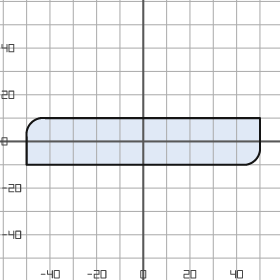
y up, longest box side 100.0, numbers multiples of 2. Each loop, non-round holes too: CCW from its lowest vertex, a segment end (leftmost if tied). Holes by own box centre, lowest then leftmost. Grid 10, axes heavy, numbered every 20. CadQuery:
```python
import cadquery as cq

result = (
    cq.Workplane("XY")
    .moveTo(-50.0, -10.0)
    .lineTo(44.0, -10.0)
    .threePointArc((48.0, -8.0), (50.0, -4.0))
    .lineTo(50.0, 10.0)
    .lineTo(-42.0, 10.0)
    .threePointArc((-48.0, 8.0), (-50.0, 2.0))
    .close()
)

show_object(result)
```